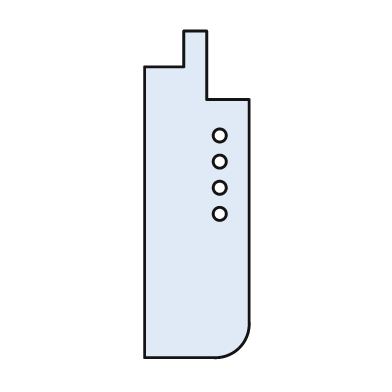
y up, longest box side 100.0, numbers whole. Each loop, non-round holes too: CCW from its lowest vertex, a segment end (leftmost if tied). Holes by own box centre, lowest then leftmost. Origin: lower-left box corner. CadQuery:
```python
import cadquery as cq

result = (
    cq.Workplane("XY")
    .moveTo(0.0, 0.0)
    .lineTo(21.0, 0.0)
    .threePointArc((29.0, 3.0), (32.0, 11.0))
    .lineTo(32.0, 79.0)
    .lineTo(19.0, 79.0)
    .lineTo(19.0, 100.0)
    .lineTo(12.0, 100.0)
    .lineTo(12.0, 89.0)
    .lineTo(0.0, 89.0)
    .close()
    .moveTo(23.0, 44.0)
    .circle(2.0)
    .moveTo(23.0, 52.0)
    .circle(2.0)
    .moveTo(23.0, 60.0)
    .circle(2.0)
    .moveTo(23.0, 68.0)
    .circle(2.0)
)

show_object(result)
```